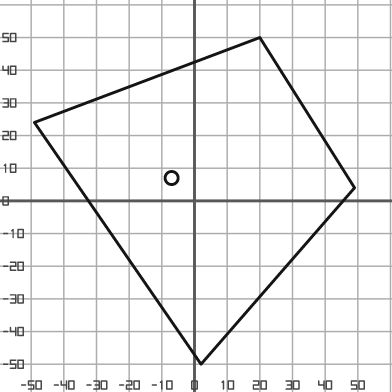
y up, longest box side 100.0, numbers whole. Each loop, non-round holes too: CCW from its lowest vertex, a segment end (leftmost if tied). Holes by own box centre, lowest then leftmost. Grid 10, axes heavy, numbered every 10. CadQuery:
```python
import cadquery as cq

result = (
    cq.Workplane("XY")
    .moveTo(2.0, -50.0)
    .lineTo(49.0, 4.0)
    .lineTo(20.0, 50.0)
    .lineTo(-49.0, 24.0)
    .close()
    .moveTo(-7.0, 7.0)
    .circle(2.0)
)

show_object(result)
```